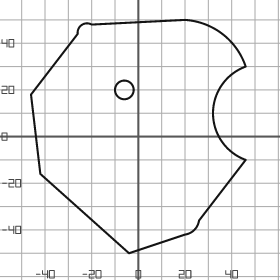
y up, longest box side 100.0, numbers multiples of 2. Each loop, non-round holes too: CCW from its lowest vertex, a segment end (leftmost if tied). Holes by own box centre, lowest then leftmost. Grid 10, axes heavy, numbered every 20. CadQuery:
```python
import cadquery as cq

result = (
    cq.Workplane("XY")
    .moveTo(-4.0, -50.0)
    .lineTo(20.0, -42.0)
    .threePointArc((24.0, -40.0), (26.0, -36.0))
    .lineTo(46.0, -10.0)
    .threePointArc((32.0, 10.0), (46.0, 30.0))
    .threePointArc((36.0, 44.0), (20.0, 50.0))
    .lineTo(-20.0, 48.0)
    .threePointArc((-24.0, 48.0), (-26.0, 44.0))
    .lineTo(-46.0, 18.0)
    .lineTo(-42.0, -16.0)
    .close()
    .moveTo(-6.0, 20.0)
    .circle(4.0)
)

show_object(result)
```